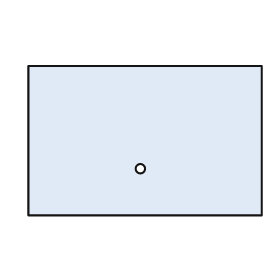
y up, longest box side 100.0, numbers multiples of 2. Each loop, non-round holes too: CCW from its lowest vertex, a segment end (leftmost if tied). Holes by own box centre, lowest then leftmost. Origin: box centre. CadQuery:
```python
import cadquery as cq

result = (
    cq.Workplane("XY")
    .moveTo(-50.0, -32.0)
    .lineTo(50.0, -32.0)
    .lineTo(50.0, 32.0)
    .lineTo(-50.0, 32.0)
    .close()
    .moveTo(-2.0, -12.0)
    .circle(2.0)
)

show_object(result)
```